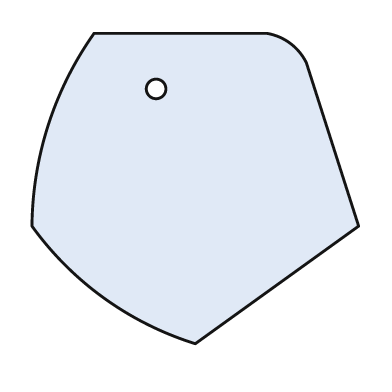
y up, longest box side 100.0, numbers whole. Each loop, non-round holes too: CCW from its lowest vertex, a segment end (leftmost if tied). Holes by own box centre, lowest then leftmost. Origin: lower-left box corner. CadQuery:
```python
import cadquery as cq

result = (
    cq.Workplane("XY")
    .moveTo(50.0, 0.0)
    .lineTo(100.0, 36.0)
    .lineTo(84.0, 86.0)
    .threePointArc((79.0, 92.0), (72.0, 95.0))
    .lineTo(19.0, 95.0)
    .threePointArc((5.0, 67.0), (0.0, 36.0))
    .threePointArc((22.0, 14.0), (50.0, 0.0))
    .close()
    .moveTo(38.0, 78.0)
    .circle(3.0)
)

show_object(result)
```